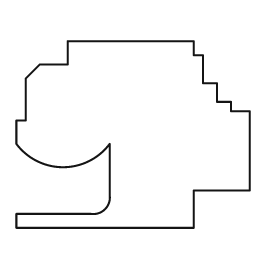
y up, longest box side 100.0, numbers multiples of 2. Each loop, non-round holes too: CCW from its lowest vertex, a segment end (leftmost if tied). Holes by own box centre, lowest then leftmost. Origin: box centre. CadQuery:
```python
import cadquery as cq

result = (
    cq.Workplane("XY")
    .moveTo(-50.0, -40.0)
    .lineTo(26.0, -40.0)
    .lineTo(26.0, -24.0)
    .lineTo(50.0, -24.0)
    .lineTo(50.0, 10.0)
    .lineTo(42.0, 10.0)
    .lineTo(42.0, 14.0)
    .lineTo(36.0, 14.0)
    .lineTo(36.0, 22.0)
    .lineTo(30.0, 22.0)
    .lineTo(30.0, 34.0)
    .lineTo(26.0, 34.0)
    .lineTo(26.0, 40.0)
    .lineTo(-28.0, 40.0)
    .lineTo(-28.0, 30.0)
    .lineTo(-40.0, 30.0)
    .lineTo(-46.0, 24.0)
    .lineTo(-46.0, 6.0)
    .lineTo(-50.0, 6.0)
    .lineTo(-50.0, -4.0)
    .threePointArc((-30.0, -14.0), (-10.0, -4.0))
    .lineTo(-10.0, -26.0)
    .threePointArc((-12.0, -32.0), (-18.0, -34.0))
    .lineTo(-50.0, -34.0)
    .close()
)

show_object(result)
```